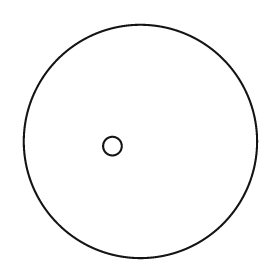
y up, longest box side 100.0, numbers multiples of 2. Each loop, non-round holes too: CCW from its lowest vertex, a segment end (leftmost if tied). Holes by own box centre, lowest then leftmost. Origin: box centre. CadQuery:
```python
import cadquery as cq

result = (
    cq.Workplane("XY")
    .moveTo(0.0, 0.0)
    .circle(50.0)
    .moveTo(-12.0, -2.0)
    .circle(4.0)
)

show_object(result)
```